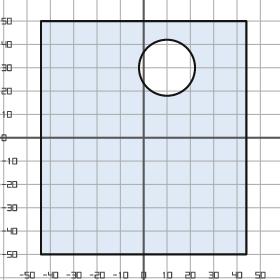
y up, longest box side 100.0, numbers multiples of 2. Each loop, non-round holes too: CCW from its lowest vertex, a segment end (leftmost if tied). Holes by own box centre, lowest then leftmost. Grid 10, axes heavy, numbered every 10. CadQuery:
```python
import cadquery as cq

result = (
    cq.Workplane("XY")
    .moveTo(-44.0, -50.0)
    .lineTo(44.0, -50.0)
    .lineTo(44.0, 50.0)
    .lineTo(-44.0, 50.0)
    .close()
    .moveTo(10.0, 30.0)
    .circle(12.0)
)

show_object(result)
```